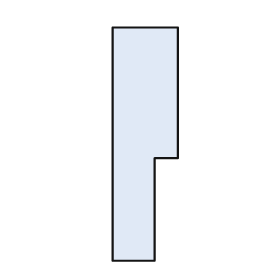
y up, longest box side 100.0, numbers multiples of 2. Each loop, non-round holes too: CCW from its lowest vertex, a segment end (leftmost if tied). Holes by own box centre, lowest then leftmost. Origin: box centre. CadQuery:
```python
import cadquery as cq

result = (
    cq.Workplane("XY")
    .moveTo(-14.0, -50.0)
    .lineTo(4.0, -50.0)
    .lineTo(4.0, -6.0)
    .lineTo(14.0, -6.0)
    .lineTo(14.0, 50.0)
    .lineTo(-14.0, 50.0)
    .close()
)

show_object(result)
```